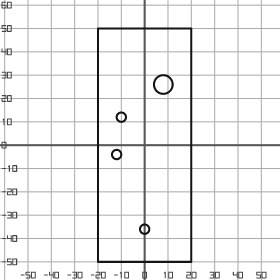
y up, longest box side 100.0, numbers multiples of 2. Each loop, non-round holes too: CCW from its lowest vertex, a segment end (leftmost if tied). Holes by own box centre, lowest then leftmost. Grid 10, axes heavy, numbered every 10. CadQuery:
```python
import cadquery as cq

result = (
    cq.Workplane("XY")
    .moveTo(-20.0, -50.0)
    .lineTo(20.0, -50.0)
    .lineTo(20.0, 50.0)
    .lineTo(-20.0, 50.0)
    .close()
    .moveTo(0.0, -36.0)
    .circle(2.0)
    .moveTo(-12.0, -4.0)
    .circle(2.0)
    .moveTo(-10.0, 12.0)
    .circle(2.0)
    .moveTo(8.0, 26.0)
    .circle(4.0)
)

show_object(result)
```